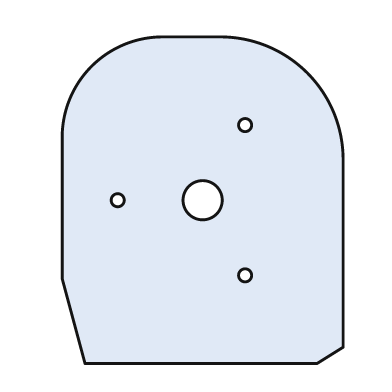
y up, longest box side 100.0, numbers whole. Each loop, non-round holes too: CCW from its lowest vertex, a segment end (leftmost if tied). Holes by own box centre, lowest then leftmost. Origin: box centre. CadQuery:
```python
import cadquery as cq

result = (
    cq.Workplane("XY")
    .moveTo(-36.0, -50.0)
    .lineTo(35.0, -50.0)
    .lineTo(43.0, -45.0)
    .lineTo(43.0, 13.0)
    .threePointArc((32.0, 39.0), (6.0, 50.0))
    .lineTo(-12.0, 50.0)
    .threePointArc((-34.0, 41.0), (-43.0, 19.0))
    .lineTo(-43.0, -24.0)
    .close()
    .moveTo(13.0, -23.0)
    .circle(2.0)
    .moveTo(-26.0, 0.0)
    .circle(2.0)
    .moveTo(0.0, 0.0)
    .circle(6.0)
    .moveTo(13.0, 23.0)
    .circle(2.0)
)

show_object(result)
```